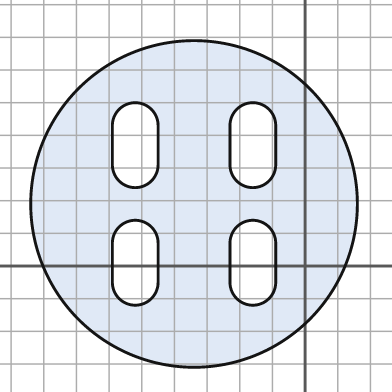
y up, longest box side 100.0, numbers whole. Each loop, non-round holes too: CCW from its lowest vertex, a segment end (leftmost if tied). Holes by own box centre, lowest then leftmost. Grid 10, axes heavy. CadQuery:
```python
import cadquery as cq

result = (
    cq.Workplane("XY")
    .moveTo(-34.0, 19.0)
    .circle(50.0)
    .moveTo(-59.0, -5.0)
    .threePointArc((-52.0, -12.0), (-45.0, -5.0))
    .lineTo(-45.0, 7.0)
    .threePointArc((-52.0, 14.0), (-59.0, 7.0))
    .close()
    .moveTo(-23.0, -5.0)
    .threePointArc((-16.0, -12.0), (-9.0, -5.0))
    .lineTo(-9.0, 7.0)
    .threePointArc((-16.0, 14.0), (-23.0, 7.0))
    .close()
    .moveTo(-59.0, 31.0)
    .threePointArc((-52.0, 24.0), (-45.0, 31.0))
    .lineTo(-45.0, 43.0)
    .threePointArc((-52.0, 50.0), (-59.0, 43.0))
    .close()
    .moveTo(-23.0, 31.0)
    .threePointArc((-16.0, 24.0), (-9.0, 31.0))
    .lineTo(-9.0, 43.0)
    .threePointArc((-16.0, 50.0), (-23.0, 43.0))
    .close()
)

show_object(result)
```